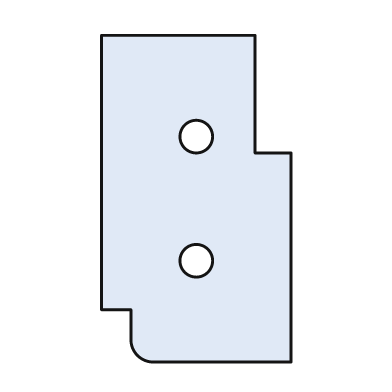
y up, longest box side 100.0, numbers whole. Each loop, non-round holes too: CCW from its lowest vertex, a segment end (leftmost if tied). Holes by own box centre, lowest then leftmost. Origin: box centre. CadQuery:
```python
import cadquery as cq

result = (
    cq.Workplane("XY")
    .moveTo(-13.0, -50.0)
    .lineTo(29.0, -50.0)
    .lineTo(29.0, 14.0)
    .lineTo(18.0, 14.0)
    .lineTo(18.0, 50.0)
    .lineTo(-29.0, 50.0)
    .lineTo(-29.0, -34.0)
    .lineTo(-20.0, -34.0)
    .lineTo(-20.0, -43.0)
    .threePointArc((-18.0, -48.0), (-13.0, -50.0))
    .close()
    .moveTo(0.0, -19.0)
    .circle(5.0)
    .moveTo(0.0, 19.0)
    .circle(5.0)
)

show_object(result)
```